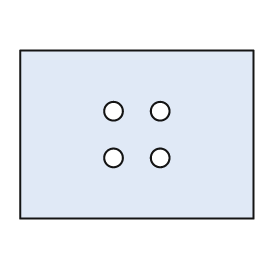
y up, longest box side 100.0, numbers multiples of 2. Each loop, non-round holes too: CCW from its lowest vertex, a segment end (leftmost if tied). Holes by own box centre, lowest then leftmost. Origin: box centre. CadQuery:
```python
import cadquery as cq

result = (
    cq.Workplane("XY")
    .moveTo(-50.0, -36.0)
    .lineTo(50.0, -36.0)
    .lineTo(50.0, 36.0)
    .lineTo(-50.0, 36.0)
    .close()
    .moveTo(-10.0, -10.0)
    .circle(4.0)
    .moveTo(10.0, -10.0)
    .circle(4.0)
    .moveTo(-10.0, 10.0)
    .circle(4.0)
    .moveTo(10.0, 10.0)
    .circle(4.0)
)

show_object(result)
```